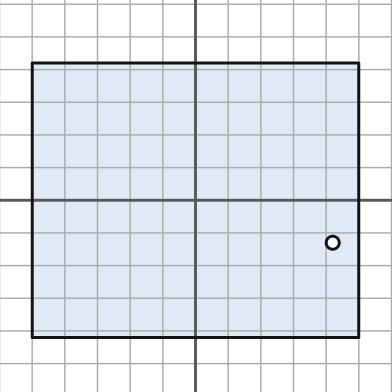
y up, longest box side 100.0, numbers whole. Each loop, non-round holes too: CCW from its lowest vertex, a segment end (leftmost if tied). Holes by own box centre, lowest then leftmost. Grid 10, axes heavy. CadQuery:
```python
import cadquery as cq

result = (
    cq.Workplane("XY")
    .moveTo(-50.0, -42.0)
    .lineTo(50.0, -42.0)
    .lineTo(50.0, 42.0)
    .lineTo(-50.0, 42.0)
    .close()
    .moveTo(42.0, -13.0)
    .circle(2.0)
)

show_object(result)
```